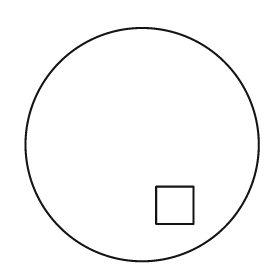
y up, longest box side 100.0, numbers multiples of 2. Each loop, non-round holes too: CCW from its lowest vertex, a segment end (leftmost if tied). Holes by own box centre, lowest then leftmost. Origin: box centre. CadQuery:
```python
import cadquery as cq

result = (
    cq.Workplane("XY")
    .moveTo(0.0, 0.0)
    .circle(50.0)
    .moveTo(6.0, -34.0)
    .lineTo(22.0, -34.0)
    .lineTo(22.0, -18.0)
    .lineTo(6.0, -18.0)
    .close()
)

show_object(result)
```